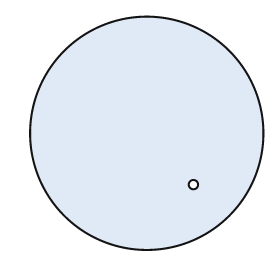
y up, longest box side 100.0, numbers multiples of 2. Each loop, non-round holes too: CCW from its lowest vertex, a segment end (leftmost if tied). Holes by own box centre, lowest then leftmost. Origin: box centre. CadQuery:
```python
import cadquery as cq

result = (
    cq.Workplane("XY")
    .moveTo(0.0, 0.0)
    .circle(50.0)
    .moveTo(20.0, -22.0)
    .circle(2.0)
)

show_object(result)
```